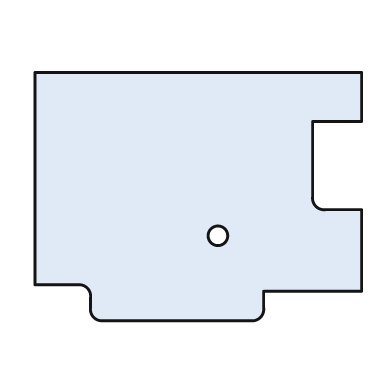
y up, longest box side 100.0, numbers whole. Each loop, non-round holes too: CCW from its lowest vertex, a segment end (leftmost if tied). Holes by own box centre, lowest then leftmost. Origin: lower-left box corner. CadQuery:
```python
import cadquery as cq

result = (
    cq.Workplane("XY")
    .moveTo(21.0, 0.0)
    .lineTo(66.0, 0.0)
    .threePointArc((69.0, 1.0), (70.0, 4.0))
    .lineTo(70.0, 9.0)
    .lineTo(100.0, 9.0)
    .lineTo(100.0, 34.0)
    .lineTo(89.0, 34.0)
    .threePointArc((86.0, 35.0), (85.0, 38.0))
    .lineTo(85.0, 61.0)
    .lineTo(100.0, 61.0)
    .lineTo(100.0, 76.0)
    .lineTo(0.0, 76.0)
    .lineTo(0.0, 11.0)
    .lineTo(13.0, 11.0)
    .threePointArc((16.0, 10.0), (17.0, 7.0))
    .lineTo(17.0, 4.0)
    .threePointArc((18.0, 1.0), (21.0, 0.0))
    .close()
    .moveTo(56.0, 26.0)
    .circle(3.0)
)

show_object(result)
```